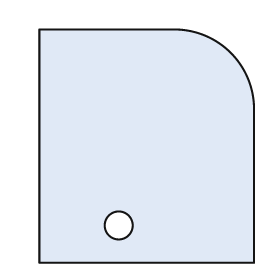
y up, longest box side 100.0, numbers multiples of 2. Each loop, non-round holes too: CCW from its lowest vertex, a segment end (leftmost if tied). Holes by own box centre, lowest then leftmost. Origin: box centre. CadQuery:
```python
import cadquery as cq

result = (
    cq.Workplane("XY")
    .moveTo(-46.0, -50.0)
    .lineTo(46.0, -50.0)
    .lineTo(46.0, 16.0)
    .threePointArc((36.0, 40.0), (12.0, 50.0))
    .lineTo(-46.0, 50.0)
    .close()
    .moveTo(-12.0, -34.0)
    .circle(6.0)
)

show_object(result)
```